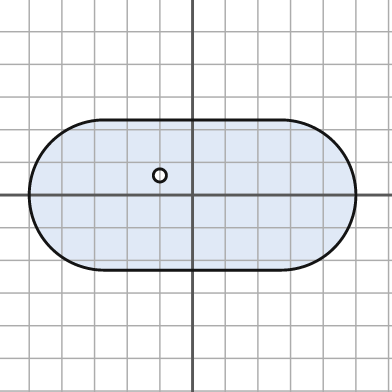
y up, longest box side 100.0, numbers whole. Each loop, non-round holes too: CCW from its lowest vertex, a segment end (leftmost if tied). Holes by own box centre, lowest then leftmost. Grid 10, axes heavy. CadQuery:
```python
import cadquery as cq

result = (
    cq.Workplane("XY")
    .moveTo(-27.0, -23.0)
    .lineTo(27.0, -23.0)
    .threePointArc((50.0, 0.0), (27.0, 23.0))
    .lineTo(-27.0, 23.0)
    .threePointArc((-50.0, 0.0), (-27.0, -23.0))
    .close()
    .moveTo(-10.0, 6.0)
    .circle(2.0)
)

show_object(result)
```